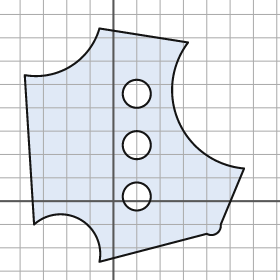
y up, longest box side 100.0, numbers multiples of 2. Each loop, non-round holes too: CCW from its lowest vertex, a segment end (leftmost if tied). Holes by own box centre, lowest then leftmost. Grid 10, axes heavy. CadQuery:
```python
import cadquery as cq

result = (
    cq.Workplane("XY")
    .moveTo(-6.0, -26.0)
    .lineTo(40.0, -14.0)
    .threePointArc((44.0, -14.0), (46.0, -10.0))
    .lineTo(56.0, 14.0)
    .threePointArc((28.0, 34.0), (32.0, 68.0))
    .lineTo(-6.0, 74.0)
    .threePointArc((-18.0, 58.0), (-38.0, 54.0))
    .lineTo(-34.0, -10.0)
    .threePointArc((-14.0, -8.0), (-6.0, -26.0))
    .close()
    .moveTo(10.0, 2.0)
    .circle(6.0)
    .moveTo(10.0, 24.0)
    .circle(6.0)
    .moveTo(10.0, 46.0)
    .circle(6.0)
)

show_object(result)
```